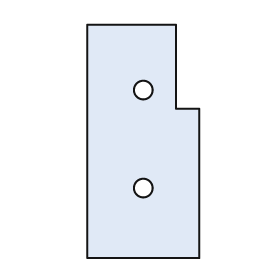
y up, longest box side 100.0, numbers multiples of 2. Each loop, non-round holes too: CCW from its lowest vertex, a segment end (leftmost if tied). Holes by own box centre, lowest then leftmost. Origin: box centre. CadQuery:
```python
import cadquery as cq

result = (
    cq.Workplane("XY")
    .moveTo(-24.0, -50.0)
    .lineTo(24.0, -50.0)
    .lineTo(24.0, 14.0)
    .lineTo(14.0, 14.0)
    .lineTo(14.0, 50.0)
    .lineTo(-24.0, 50.0)
    .close()
    .moveTo(0.0, -20.0)
    .circle(4.0)
    .moveTo(0.0, 22.0)
    .circle(4.0)
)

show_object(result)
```